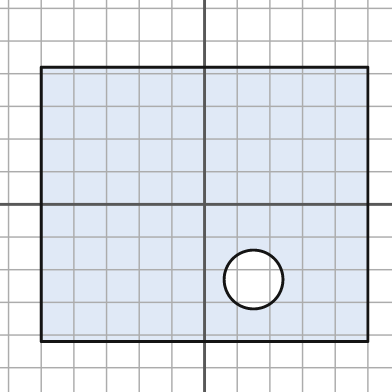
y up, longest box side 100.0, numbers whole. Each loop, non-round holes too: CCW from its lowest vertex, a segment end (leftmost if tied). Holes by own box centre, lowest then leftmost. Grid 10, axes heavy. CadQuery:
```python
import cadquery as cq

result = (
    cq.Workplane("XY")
    .moveTo(-50.0, -42.0)
    .lineTo(50.0, -42.0)
    .lineTo(50.0, 42.0)
    .lineTo(-50.0, 42.0)
    .close()
    .moveTo(15.0, -23.0)
    .circle(9.0)
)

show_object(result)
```